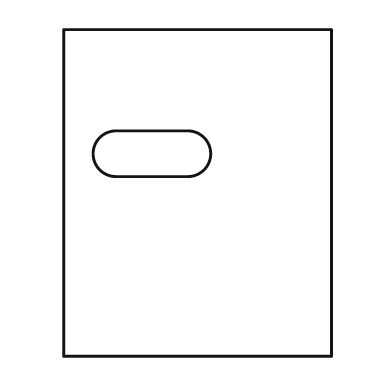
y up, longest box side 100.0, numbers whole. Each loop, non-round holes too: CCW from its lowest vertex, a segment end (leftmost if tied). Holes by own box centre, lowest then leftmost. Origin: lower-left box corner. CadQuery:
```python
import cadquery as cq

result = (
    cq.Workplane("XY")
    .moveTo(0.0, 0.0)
    .lineTo(82.0, 0.0)
    .lineTo(82.0, 100.0)
    .lineTo(0.0, 100.0)
    .close()
    .moveTo(16.0, 55.0)
    .lineTo(38.0, 55.0)
    .threePointArc((45.0, 62.0), (38.0, 69.0))
    .lineTo(16.0, 69.0)
    .threePointArc((9.0, 62.0), (16.0, 55.0))
    .close()
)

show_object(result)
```